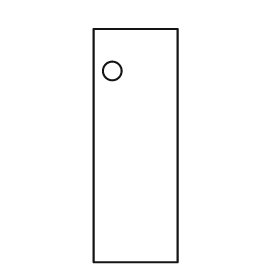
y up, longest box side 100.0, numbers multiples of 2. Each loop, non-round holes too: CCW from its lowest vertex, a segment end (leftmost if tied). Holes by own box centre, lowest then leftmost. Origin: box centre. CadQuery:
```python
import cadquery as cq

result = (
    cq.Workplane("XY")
    .moveTo(-18.0, -50.0)
    .lineTo(18.0, -50.0)
    .lineTo(18.0, 50.0)
    .lineTo(-18.0, 50.0)
    .close()
    .moveTo(-10.0, 32.0)
    .circle(4.0)
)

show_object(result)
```